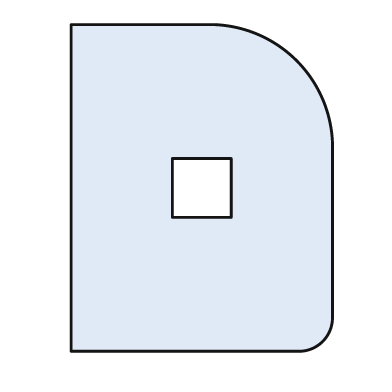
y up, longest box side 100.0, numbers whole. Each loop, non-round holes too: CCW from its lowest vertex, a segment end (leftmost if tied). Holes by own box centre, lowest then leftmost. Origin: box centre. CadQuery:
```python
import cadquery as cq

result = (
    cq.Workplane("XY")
    .moveTo(-40.0, -50.0)
    .lineTo(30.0, -50.0)
    .threePointArc((37.0, -47.0), (40.0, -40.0))
    .lineTo(40.0, 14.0)
    .threePointArc((29.0, 39.0), (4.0, 50.0))
    .lineTo(-40.0, 50.0)
    .close()
    .moveTo(-9.0, -9.0)
    .lineTo(9.0, -9.0)
    .lineTo(9.0, 9.0)
    .lineTo(-9.0, 9.0)
    .close()
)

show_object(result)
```